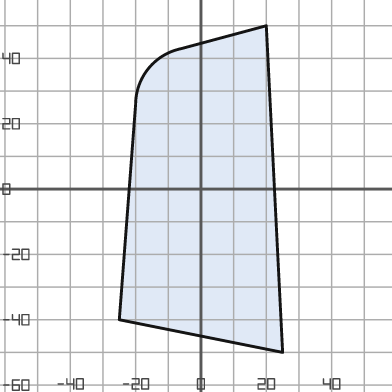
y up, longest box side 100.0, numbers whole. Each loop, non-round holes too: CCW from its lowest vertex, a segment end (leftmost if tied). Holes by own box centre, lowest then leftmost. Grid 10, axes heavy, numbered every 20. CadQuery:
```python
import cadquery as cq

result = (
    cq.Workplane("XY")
    .moveTo(25.0, -50.0)
    .lineTo(20.0, 50.0)
    .lineTo(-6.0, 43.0)
    .threePointArc((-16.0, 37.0), (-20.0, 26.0))
    .lineTo(-25.0, -40.0)
    .close()
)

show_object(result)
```